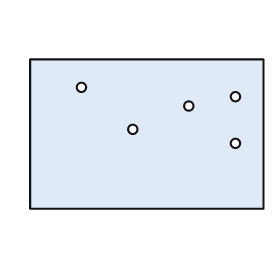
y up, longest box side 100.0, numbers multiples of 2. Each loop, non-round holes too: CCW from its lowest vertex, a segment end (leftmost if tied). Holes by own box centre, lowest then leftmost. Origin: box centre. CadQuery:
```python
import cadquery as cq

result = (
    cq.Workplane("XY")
    .moveTo(-50.0, -32.0)
    .lineTo(50.0, -32.0)
    .lineTo(50.0, 32.0)
    .lineTo(-50.0, 32.0)
    .close()
    .moveTo(38.0, -4.0)
    .circle(2.0)
    .moveTo(-6.0, 2.0)
    .circle(2.0)
    .moveTo(18.0, 12.0)
    .circle(2.0)
    .moveTo(38.0, 16.0)
    .circle(2.0)
    .moveTo(-28.0, 20.0)
    .circle(2.0)
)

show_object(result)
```